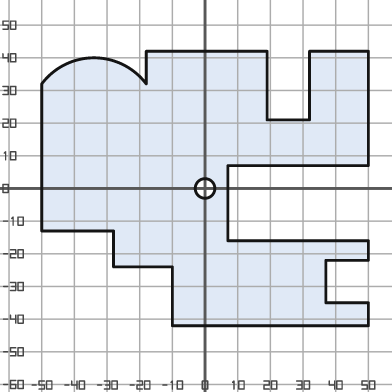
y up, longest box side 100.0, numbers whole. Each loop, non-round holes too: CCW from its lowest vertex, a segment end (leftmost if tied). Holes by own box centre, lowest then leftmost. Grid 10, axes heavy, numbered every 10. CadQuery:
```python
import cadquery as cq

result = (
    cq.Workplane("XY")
    .moveTo(-10.0, -42.0)
    .lineTo(50.0, -42.0)
    .lineTo(50.0, -35.0)
    .lineTo(37.0, -35.0)
    .lineTo(37.0, -22.0)
    .lineTo(50.0, -22.0)
    .lineTo(50.0, -16.0)
    .lineTo(7.0, -16.0)
    .lineTo(7.0, 7.0)
    .lineTo(50.0, 7.0)
    .lineTo(50.0, 42.0)
    .lineTo(32.0, 42.0)
    .lineTo(32.0, 21.0)
    .lineTo(19.0, 21.0)
    .lineTo(19.0, 42.0)
    .lineTo(-18.0, 42.0)
    .lineTo(-18.0, 32.0)
    .threePointArc((-34.0, 40.0), (-50.0, 32.0))
    .lineTo(-50.0, -13.0)
    .lineTo(-28.0, -13.0)
    .lineTo(-28.0, -24.0)
    .lineTo(-10.0, -24.0)
    .close()
    .moveTo(0.0, 0.0)
    .circle(3.0)
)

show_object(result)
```